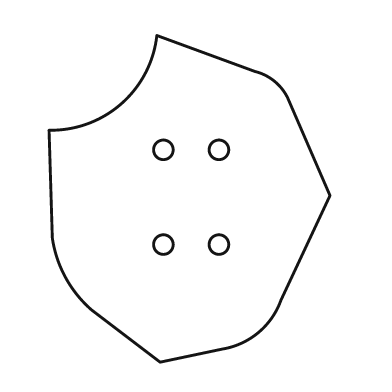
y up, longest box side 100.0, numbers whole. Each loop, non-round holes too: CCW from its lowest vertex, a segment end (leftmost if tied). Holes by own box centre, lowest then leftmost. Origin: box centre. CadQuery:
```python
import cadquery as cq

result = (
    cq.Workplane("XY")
    .moveTo(-9.0, -50.0)
    .lineTo(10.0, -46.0)
    .threePointArc((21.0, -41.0), (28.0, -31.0))
    .lineTo(43.0, 1.0)
    .lineTo(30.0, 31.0)
    .threePointArc((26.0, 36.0), (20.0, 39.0))
    .lineTo(-10.0, 50.0)
    .threePointArc((-21.0, 29.0), (-43.0, 21.0))
    .lineTo(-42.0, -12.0)
    .threePointArc((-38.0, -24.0), (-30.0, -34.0))
    .close()
    .moveTo(-8.0, -14.0)
    .circle(3.0)
    .moveTo(9.0, -14.0)
    .circle(3.0)
    .moveTo(-8.0, 15.0)
    .circle(3.0)
    .moveTo(9.0, 15.0)
    .circle(3.0)
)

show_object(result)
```